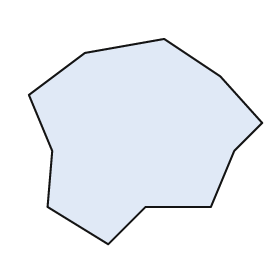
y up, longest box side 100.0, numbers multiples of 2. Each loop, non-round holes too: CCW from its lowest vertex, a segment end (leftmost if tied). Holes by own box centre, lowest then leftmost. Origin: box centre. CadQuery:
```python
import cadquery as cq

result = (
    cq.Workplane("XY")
    .moveTo(-16.0, -44.0)
    .lineTo(0.0, -28.0)
    .lineTo(28.0, -28.0)
    .lineTo(38.0, -4.0)
    .lineTo(50.0, 8.0)
    .lineTo(32.0, 28.0)
    .lineTo(8.0, 44.0)
    .lineTo(-26.0, 38.0)
    .lineTo(-50.0, 20.0)
    .lineTo(-40.0, -4.0)
    .lineTo(-42.0, -28.0)
    .close()
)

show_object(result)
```